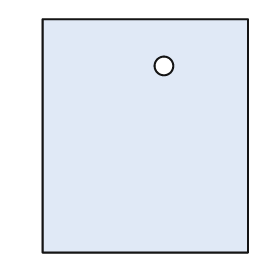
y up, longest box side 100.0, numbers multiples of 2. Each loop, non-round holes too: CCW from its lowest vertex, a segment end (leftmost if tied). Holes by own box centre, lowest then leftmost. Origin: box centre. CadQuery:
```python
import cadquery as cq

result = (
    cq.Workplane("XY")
    .moveTo(-44.0, -50.0)
    .lineTo(44.0, -50.0)
    .lineTo(44.0, 50.0)
    .lineTo(-44.0, 50.0)
    .close()
    .moveTo(8.0, 30.0)
    .circle(4.0)
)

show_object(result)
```